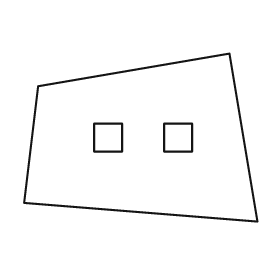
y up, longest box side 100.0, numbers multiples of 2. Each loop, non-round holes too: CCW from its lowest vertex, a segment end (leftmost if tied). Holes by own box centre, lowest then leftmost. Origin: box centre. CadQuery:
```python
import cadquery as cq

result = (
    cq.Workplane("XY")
    .moveTo(50.0, -36.0)
    .lineTo(38.0, 36.0)
    .lineTo(-44.0, 22.0)
    .lineTo(-50.0, -28.0)
    .close()
    .moveTo(-20.0, -6.0)
    .lineTo(-8.0, -6.0)
    .lineTo(-8.0, 6.0)
    .lineTo(-20.0, 6.0)
    .close()
    .moveTo(10.0, -6.0)
    .lineTo(22.0, -6.0)
    .lineTo(22.0, 6.0)
    .lineTo(10.0, 6.0)
    .close()
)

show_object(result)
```